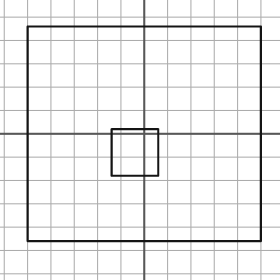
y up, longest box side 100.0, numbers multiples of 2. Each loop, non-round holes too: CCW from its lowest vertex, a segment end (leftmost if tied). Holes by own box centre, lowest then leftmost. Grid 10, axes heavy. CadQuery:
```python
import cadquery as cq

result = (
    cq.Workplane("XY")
    .moveTo(-50.0, -46.0)
    .lineTo(50.0, -46.0)
    .lineTo(50.0, 46.0)
    .lineTo(-50.0, 46.0)
    .close()
    .moveTo(-14.0, -18.0)
    .lineTo(6.0, -18.0)
    .lineTo(6.0, 2.0)
    .lineTo(-14.0, 2.0)
    .close()
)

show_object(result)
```